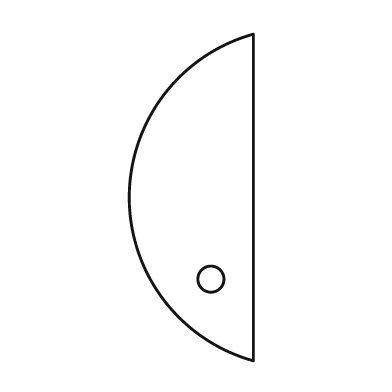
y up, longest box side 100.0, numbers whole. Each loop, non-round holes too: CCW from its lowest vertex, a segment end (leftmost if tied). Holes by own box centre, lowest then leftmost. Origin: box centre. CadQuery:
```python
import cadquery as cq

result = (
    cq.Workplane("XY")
    .moveTo(19.0, -50.0)
    .lineTo(19.0, 50.0)
    .threePointArc((-19.0, 0.0), (19.0, -50.0))
    .close()
    .moveTo(6.0, -25.0)
    .circle(4.0)
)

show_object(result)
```